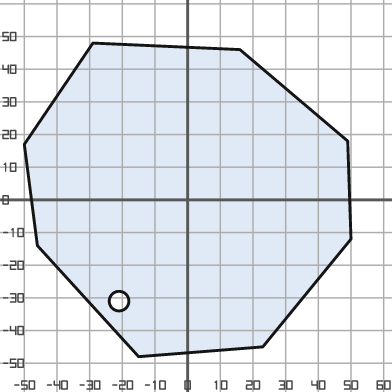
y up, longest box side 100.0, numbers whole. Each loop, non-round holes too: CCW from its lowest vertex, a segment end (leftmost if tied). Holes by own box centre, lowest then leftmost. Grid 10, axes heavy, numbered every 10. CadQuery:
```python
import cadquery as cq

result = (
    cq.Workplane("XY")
    .moveTo(-15.0, -48.0)
    .lineTo(23.0, -45.0)
    .lineTo(50.0, -12.0)
    .lineTo(49.0, 18.0)
    .lineTo(16.0, 46.0)
    .lineTo(-29.0, 48.0)
    .lineTo(-50.0, 17.0)
    .lineTo(-46.0, -14.0)
    .close()
    .moveTo(-21.0, -31.0)
    .circle(3.0)
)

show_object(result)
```